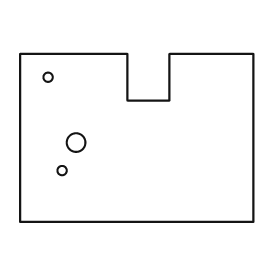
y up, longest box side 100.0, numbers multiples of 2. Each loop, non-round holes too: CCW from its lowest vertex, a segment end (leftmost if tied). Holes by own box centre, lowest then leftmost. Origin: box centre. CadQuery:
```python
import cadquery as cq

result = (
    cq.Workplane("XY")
    .moveTo(-50.0, -36.0)
    .lineTo(50.0, -36.0)
    .lineTo(50.0, 36.0)
    .lineTo(14.0, 36.0)
    .lineTo(14.0, 16.0)
    .lineTo(-4.0, 16.0)
    .lineTo(-4.0, 36.0)
    .lineTo(-50.0, 36.0)
    .close()
    .moveTo(-32.0, -14.0)
    .circle(2.0)
    .moveTo(-26.0, -2.0)
    .circle(4.0)
    .moveTo(-38.0, 26.0)
    .circle(2.0)
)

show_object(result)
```